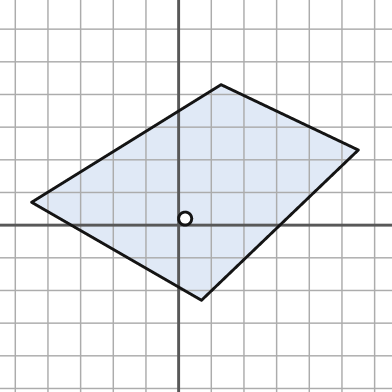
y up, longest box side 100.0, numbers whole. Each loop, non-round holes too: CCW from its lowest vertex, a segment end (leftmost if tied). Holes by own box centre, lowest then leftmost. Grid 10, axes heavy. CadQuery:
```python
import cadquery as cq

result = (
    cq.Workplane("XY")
    .moveTo(7.0, -23.0)
    .lineTo(55.0, 23.0)
    .lineTo(13.0, 43.0)
    .lineTo(-45.0, 7.0)
    .close()
    .moveTo(2.0, 2.0)
    .circle(2.0)
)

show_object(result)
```